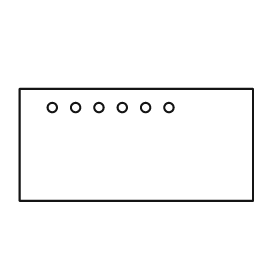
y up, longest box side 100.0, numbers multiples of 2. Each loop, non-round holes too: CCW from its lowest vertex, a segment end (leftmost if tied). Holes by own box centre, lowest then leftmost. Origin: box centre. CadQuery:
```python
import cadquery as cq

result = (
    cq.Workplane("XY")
    .moveTo(-50.0, -24.0)
    .lineTo(50.0, -24.0)
    .lineTo(50.0, 24.0)
    .lineTo(-50.0, 24.0)
    .close()
    .moveTo(-36.0, 16.0)
    .circle(2.0)
    .moveTo(-26.0, 16.0)
    .circle(2.0)
    .moveTo(-16.0, 16.0)
    .circle(2.0)
    .moveTo(-6.0, 16.0)
    .circle(2.0)
    .moveTo(4.0, 16.0)
    .circle(2.0)
    .moveTo(14.0, 16.0)
    .circle(2.0)
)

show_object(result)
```